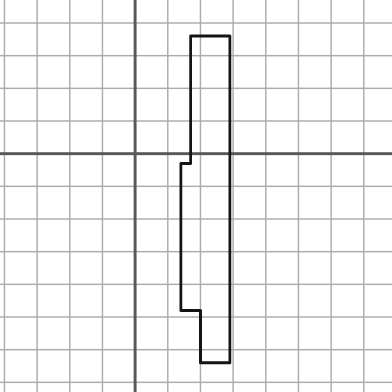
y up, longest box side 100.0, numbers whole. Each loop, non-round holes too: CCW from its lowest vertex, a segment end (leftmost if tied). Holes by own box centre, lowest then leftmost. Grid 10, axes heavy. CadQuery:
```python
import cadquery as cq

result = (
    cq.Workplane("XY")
    .moveTo(20.0, -64.0)
    .lineTo(29.0, -64.0)
    .lineTo(29.0, 36.0)
    .lineTo(17.0, 36.0)
    .lineTo(17.0, -3.0)
    .lineTo(14.0, -3.0)
    .lineTo(14.0, -48.0)
    .lineTo(20.0, -48.0)
    .close()
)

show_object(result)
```